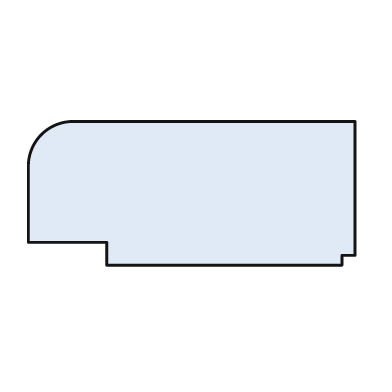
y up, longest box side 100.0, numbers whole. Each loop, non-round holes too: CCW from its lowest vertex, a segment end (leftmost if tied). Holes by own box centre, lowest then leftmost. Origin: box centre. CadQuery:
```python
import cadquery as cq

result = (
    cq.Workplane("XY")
    .moveTo(-26.0, -22.0)
    .lineTo(46.0, -22.0)
    .lineTo(46.0, -19.0)
    .lineTo(50.0, -19.0)
    .lineTo(50.0, 22.0)
    .lineTo(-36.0, 22.0)
    .threePointArc((-46.0, 18.0), (-50.0, 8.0))
    .lineTo(-50.0, -15.0)
    .lineTo(-26.0, -15.0)
    .close()
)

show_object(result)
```